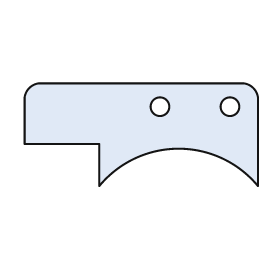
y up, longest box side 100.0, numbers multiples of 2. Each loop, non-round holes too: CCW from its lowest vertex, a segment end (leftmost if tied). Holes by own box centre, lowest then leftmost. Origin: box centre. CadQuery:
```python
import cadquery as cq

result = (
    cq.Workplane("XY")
    .moveTo(-18.0, -22.0)
    .threePointArc((16.0, -6.0), (50.0, -22.0))
    .lineTo(50.0, 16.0)
    .threePointArc((48.0, 20.0), (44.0, 22.0))
    .lineTo(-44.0, 22.0)
    .threePointArc((-48.0, 20.0), (-50.0, 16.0))
    .lineTo(-50.0, -4.0)
    .lineTo(-18.0, -4.0)
    .close()
    .moveTo(8.0, 12.0)
    .circle(4.0)
    .moveTo(38.0, 12.0)
    .circle(4.0)
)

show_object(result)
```